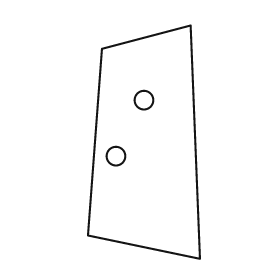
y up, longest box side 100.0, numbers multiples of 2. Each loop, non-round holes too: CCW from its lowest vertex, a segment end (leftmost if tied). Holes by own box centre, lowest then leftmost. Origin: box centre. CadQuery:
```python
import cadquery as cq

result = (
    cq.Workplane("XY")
    .moveTo(24.0, -50.0)
    .lineTo(20.0, 50.0)
    .lineTo(-18.0, 40.0)
    .lineTo(-24.0, -40.0)
    .close()
    .moveTo(-12.0, -6.0)
    .circle(4.0)
    .moveTo(0.0, 18.0)
    .circle(4.0)
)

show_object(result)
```